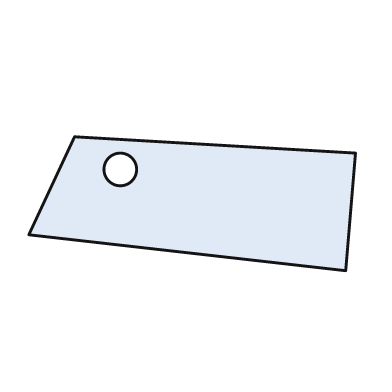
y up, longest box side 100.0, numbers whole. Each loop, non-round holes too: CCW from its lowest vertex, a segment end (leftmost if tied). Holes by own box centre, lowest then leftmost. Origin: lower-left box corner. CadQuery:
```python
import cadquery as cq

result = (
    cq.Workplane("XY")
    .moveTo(97.0, 0.0)
    .lineTo(100.0, 36.0)
    .lineTo(14.0, 41.0)
    .lineTo(0.0, 11.0)
    .close()
    .moveTo(28.0, 31.0)
    .circle(5.0)
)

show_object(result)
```